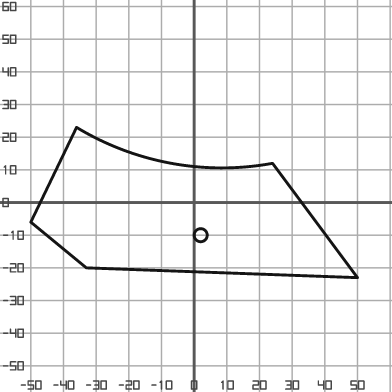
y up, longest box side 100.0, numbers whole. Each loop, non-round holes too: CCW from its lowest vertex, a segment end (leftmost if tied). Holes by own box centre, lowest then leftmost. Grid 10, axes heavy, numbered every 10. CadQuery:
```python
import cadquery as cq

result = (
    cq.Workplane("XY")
    .moveTo(50.0, -23.0)
    .lineTo(24.0, 12.0)
    .threePointArc((-7.0, 12.0), (-36.0, 23.0))
    .lineTo(-50.0, -6.0)
    .lineTo(-33.0, -20.0)
    .close()
    .moveTo(2.0, -10.0)
    .circle(2.0)
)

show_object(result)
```